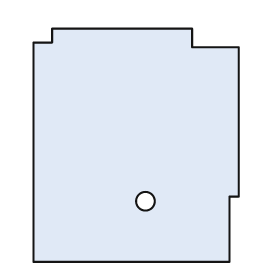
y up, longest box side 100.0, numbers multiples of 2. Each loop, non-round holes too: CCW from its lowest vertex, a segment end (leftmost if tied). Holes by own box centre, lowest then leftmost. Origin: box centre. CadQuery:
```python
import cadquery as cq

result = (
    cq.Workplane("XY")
    .moveTo(-44.0, -50.0)
    .lineTo(40.0, -50.0)
    .lineTo(40.0, -22.0)
    .lineTo(44.0, -22.0)
    .lineTo(44.0, 42.0)
    .lineTo(24.0, 42.0)
    .lineTo(24.0, 50.0)
    .lineTo(-36.0, 50.0)
    .lineTo(-36.0, 44.0)
    .lineTo(-44.0, 44.0)
    .close()
    .moveTo(4.0, -24.0)
    .circle(4.0)
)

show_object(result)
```